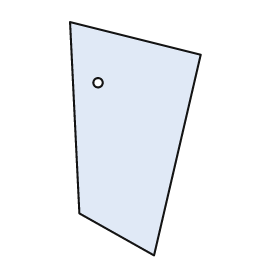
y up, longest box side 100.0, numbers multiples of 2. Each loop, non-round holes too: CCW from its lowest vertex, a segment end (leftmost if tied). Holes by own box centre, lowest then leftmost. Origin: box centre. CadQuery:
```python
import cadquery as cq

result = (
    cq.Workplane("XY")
    .moveTo(8.0, -50.0)
    .lineTo(28.0, 36.0)
    .lineTo(-28.0, 50.0)
    .lineTo(-24.0, -32.0)
    .close()
    .moveTo(-16.0, 24.0)
    .circle(2.0)
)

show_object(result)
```